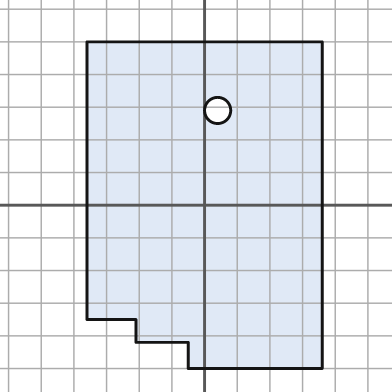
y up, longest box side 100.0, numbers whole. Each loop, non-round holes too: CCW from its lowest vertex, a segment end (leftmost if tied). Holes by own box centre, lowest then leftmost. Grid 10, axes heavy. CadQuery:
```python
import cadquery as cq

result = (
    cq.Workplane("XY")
    .moveTo(-5.0, -50.0)
    .lineTo(36.0, -50.0)
    .lineTo(36.0, 50.0)
    .lineTo(-36.0, 50.0)
    .lineTo(-36.0, -35.0)
    .lineTo(-21.0, -35.0)
    .lineTo(-21.0, -42.0)
    .lineTo(-5.0, -42.0)
    .close()
    .moveTo(4.0, 29.0)
    .circle(4.0)
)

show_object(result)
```